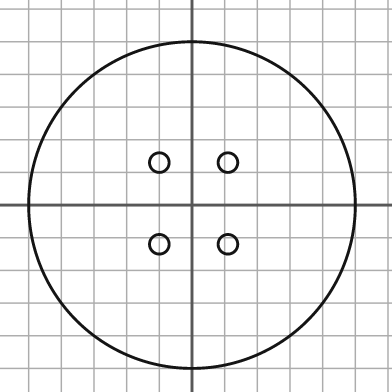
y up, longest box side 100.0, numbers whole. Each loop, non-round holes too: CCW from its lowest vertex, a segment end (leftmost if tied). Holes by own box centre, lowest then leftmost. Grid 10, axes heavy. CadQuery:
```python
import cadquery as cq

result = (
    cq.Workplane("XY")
    .moveTo(0.0, 0.0)
    .circle(50.0)
    .moveTo(-10.0, -12.0)
    .circle(3.0)
    .moveTo(11.0, -12.0)
    .circle(3.0)
    .moveTo(-10.0, 13.0)
    .circle(3.0)
    .moveTo(11.0, 13.0)
    .circle(3.0)
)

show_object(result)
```